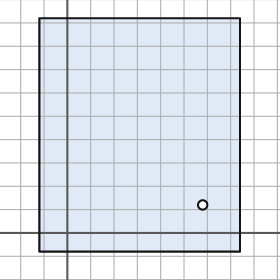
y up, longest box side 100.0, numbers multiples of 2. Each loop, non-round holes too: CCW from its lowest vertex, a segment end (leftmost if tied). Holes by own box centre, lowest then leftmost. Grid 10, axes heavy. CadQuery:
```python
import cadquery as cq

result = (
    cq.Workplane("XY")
    .moveTo(-12.0, -8.0)
    .lineTo(74.0, -8.0)
    .lineTo(74.0, 92.0)
    .lineTo(-12.0, 92.0)
    .close()
    .moveTo(58.0, 12.0)
    .circle(2.0)
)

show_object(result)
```